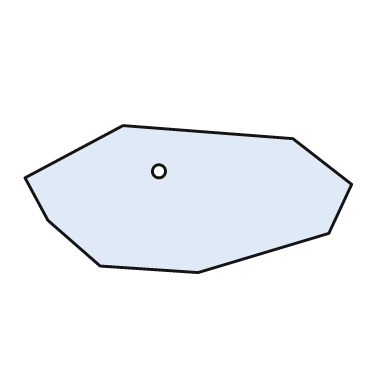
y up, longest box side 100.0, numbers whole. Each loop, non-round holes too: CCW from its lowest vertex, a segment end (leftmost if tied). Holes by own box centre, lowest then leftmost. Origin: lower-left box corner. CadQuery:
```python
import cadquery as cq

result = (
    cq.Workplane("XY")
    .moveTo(53.0, 0.0)
    .lineTo(93.0, 12.0)
    .lineTo(100.0, 27.0)
    .lineTo(82.0, 41.0)
    .lineTo(30.0, 45.0)
    .lineTo(0.0, 29.0)
    .lineTo(7.0, 16.0)
    .lineTo(23.0, 2.0)
    .close()
    .moveTo(41.0, 31.0)
    .circle(2.0)
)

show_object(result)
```